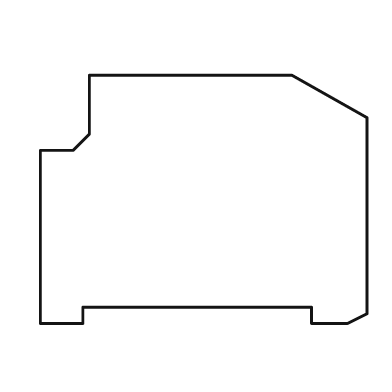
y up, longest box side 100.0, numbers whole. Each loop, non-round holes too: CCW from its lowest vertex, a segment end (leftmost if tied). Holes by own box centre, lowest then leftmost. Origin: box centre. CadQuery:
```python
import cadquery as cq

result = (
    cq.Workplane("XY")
    .moveTo(-50.0, -38.0)
    .lineTo(-37.0, -38.0)
    .lineTo(-37.0, -33.0)
    .lineTo(33.0, -33.0)
    .lineTo(33.0, -38.0)
    .lineTo(44.0, -38.0)
    .lineTo(50.0, -35.0)
    .lineTo(50.0, 25.0)
    .lineTo(27.0, 38.0)
    .lineTo(-35.0, 38.0)
    .lineTo(-35.0, 20.0)
    .lineTo(-40.0, 15.0)
    .lineTo(-50.0, 15.0)
    .close()
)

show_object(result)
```